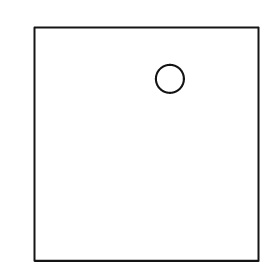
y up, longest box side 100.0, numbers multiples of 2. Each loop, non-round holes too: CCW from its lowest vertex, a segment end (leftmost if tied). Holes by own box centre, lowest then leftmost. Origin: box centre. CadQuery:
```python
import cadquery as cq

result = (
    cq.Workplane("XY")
    .moveTo(-48.0, -50.0)
    .lineTo(48.0, -50.0)
    .lineTo(48.0, 50.0)
    .lineTo(-48.0, 50.0)
    .close()
    .moveTo(10.0, 28.0)
    .circle(6.0)
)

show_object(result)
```